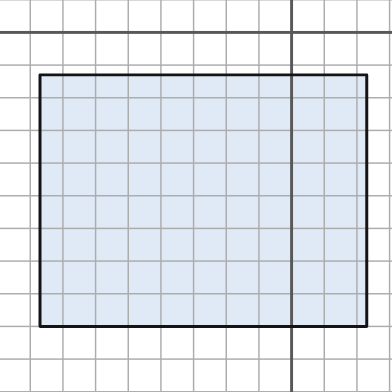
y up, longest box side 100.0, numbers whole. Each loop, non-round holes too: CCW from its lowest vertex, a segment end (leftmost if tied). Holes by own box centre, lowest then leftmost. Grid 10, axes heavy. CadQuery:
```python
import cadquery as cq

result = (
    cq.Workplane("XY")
    .moveTo(-77.0, -90.0)
    .lineTo(23.0, -90.0)
    .lineTo(23.0, -13.0)
    .lineTo(-77.0, -13.0)
    .close()
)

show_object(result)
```